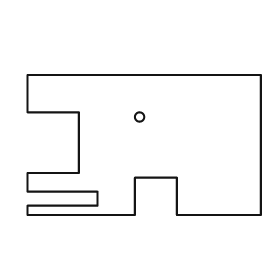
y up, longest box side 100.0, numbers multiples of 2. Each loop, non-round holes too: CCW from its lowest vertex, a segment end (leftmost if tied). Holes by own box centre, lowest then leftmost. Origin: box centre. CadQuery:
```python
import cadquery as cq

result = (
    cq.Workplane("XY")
    .moveTo(-50.0, -30.0)
    .lineTo(-4.0, -30.0)
    .lineTo(-4.0, -14.0)
    .lineTo(14.0, -14.0)
    .lineTo(14.0, -30.0)
    .lineTo(50.0, -30.0)
    .lineTo(50.0, 30.0)
    .lineTo(-50.0, 30.0)
    .lineTo(-50.0, 14.0)
    .lineTo(-28.0, 14.0)
    .lineTo(-28.0, -12.0)
    .lineTo(-50.0, -12.0)
    .lineTo(-50.0, -20.0)
    .lineTo(-20.0, -20.0)
    .lineTo(-20.0, -26.0)
    .lineTo(-50.0, -26.0)
    .close()
    .moveTo(-2.0, 12.0)
    .circle(2.0)
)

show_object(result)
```